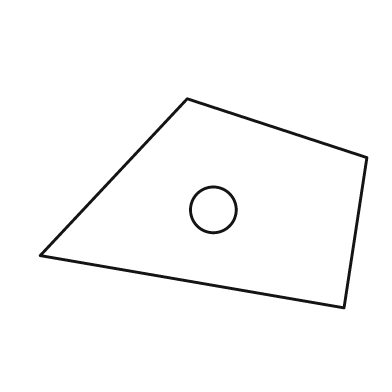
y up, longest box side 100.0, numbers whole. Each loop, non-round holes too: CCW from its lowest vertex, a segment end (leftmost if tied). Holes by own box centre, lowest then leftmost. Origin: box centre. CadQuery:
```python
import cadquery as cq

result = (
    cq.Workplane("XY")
    .moveTo(43.0, -32.0)
    .lineTo(50.0, 14.0)
    .lineTo(-5.0, 32.0)
    .lineTo(-50.0, -16.0)
    .close()
    .moveTo(3.0, -2.0)
    .circle(7.0)
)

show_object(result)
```